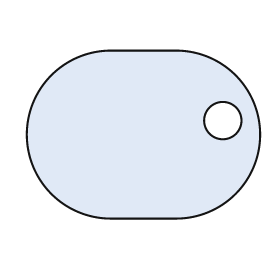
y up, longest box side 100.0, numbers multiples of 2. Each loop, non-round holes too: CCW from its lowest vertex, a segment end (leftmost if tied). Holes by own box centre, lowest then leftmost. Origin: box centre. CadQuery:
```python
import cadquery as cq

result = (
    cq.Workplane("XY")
    .moveTo(-14.0, -36.0)
    .lineTo(14.0, -36.0)
    .threePointArc((50.0, 0.0), (14.0, 36.0))
    .lineTo(-14.0, 36.0)
    .threePointArc((-50.0, 0.0), (-14.0, -36.0))
    .close()
    .moveTo(34.0, 6.0)
    .circle(8.0)
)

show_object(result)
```